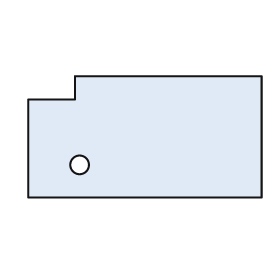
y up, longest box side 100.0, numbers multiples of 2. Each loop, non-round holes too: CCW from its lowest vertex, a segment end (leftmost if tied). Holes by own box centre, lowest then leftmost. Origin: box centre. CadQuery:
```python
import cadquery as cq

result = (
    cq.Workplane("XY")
    .moveTo(-50.0, -26.0)
    .lineTo(50.0, -26.0)
    .lineTo(50.0, 26.0)
    .lineTo(-30.0, 26.0)
    .lineTo(-30.0, 16.0)
    .lineTo(-50.0, 16.0)
    .close()
    .moveTo(-28.0, -12.0)
    .circle(4.0)
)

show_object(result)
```